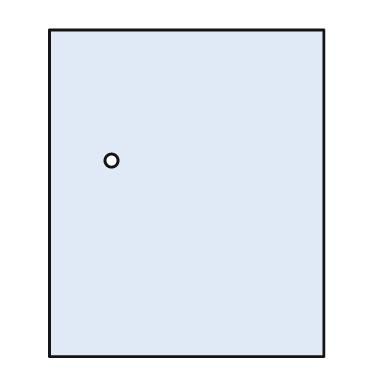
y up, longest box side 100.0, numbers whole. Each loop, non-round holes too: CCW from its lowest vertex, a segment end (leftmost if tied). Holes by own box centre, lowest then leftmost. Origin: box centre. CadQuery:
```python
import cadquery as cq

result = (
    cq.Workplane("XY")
    .moveTo(-42.0, -50.0)
    .lineTo(42.0, -50.0)
    .lineTo(42.0, 50.0)
    .lineTo(-42.0, 50.0)
    .close()
    .moveTo(-23.0, 10.0)
    .circle(2.0)
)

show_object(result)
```